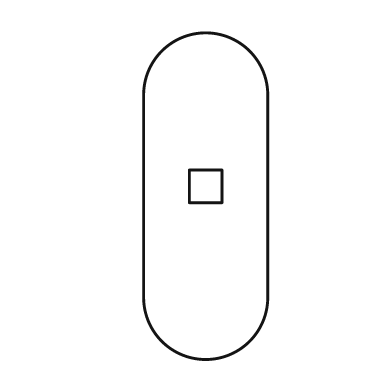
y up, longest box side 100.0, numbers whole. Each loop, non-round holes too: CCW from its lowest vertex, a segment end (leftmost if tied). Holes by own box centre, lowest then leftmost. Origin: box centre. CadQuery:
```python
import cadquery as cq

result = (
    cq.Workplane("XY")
    .moveTo(-19.0, -31.0)
    .threePointArc((0.0, -50.0), (19.0, -31.0))
    .lineTo(19.0, 31.0)
    .threePointArc((0.0, 50.0), (-19.0, 31.0))
    .close()
    .moveTo(-5.0, -2.0)
    .lineTo(5.0, -2.0)
    .lineTo(5.0, 8.0)
    .lineTo(-5.0, 8.0)
    .close()
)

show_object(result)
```